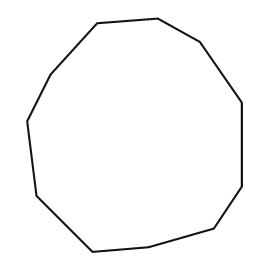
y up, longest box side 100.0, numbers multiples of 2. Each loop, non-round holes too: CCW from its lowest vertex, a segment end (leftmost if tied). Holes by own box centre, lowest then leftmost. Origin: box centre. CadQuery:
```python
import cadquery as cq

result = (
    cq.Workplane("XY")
    .moveTo(-18.0, -50.0)
    .lineTo(6.0, -48.0)
    .lineTo(34.0, -40.0)
    .lineTo(46.0, -22.0)
    .lineTo(46.0, 14.0)
    .lineTo(28.0, 40.0)
    .lineTo(10.0, 50.0)
    .lineTo(-16.0, 48.0)
    .lineTo(-36.0, 26.0)
    .lineTo(-46.0, 6.0)
    .lineTo(-42.0, -26.0)
    .close()
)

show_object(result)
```